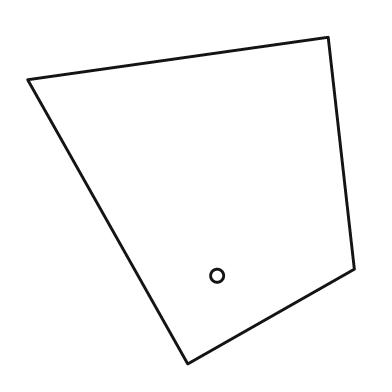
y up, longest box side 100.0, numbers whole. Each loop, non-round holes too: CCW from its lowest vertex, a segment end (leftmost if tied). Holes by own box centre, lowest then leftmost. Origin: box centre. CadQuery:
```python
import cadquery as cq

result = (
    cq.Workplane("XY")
    .moveTo(-1.0, -50.0)
    .lineTo(50.0, -21.0)
    .lineTo(42.0, 50.0)
    .lineTo(-50.0, 37.0)
    .close()
    .moveTo(8.0, -23.0)
    .circle(2.0)
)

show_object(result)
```